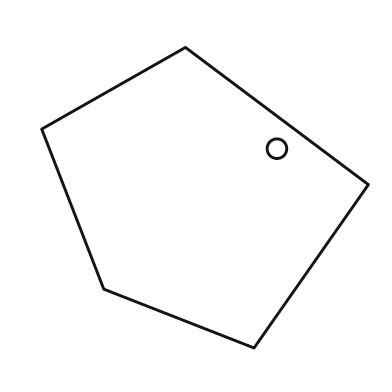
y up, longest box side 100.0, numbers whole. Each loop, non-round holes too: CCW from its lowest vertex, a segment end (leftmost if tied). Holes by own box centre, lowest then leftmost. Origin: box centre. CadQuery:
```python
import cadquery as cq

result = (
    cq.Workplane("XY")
    .moveTo(15.0, -46.0)
    .lineTo(50.0, 4.0)
    .lineTo(-6.0, 46.0)
    .lineTo(-50.0, 21.0)
    .lineTo(-31.0, -28.0)
    .close()
    .moveTo(22.0, 15.0)
    .circle(3.0)
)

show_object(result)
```